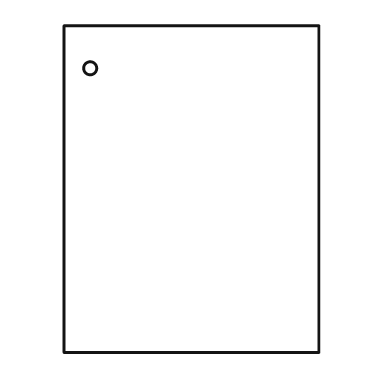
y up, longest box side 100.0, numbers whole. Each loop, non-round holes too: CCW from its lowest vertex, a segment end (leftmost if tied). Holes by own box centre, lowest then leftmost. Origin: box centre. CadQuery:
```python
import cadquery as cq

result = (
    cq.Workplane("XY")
    .moveTo(-39.0, -50.0)
    .lineTo(39.0, -50.0)
    .lineTo(39.0, 50.0)
    .lineTo(-39.0, 50.0)
    .close()
    .moveTo(-31.0, 37.0)
    .circle(2.0)
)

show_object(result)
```